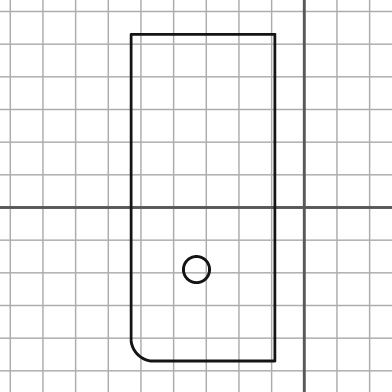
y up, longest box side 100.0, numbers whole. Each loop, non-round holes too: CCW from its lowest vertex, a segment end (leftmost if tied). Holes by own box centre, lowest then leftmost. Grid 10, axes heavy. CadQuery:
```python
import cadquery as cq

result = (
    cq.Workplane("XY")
    .moveTo(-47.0, -47.0)
    .lineTo(-9.0, -47.0)
    .lineTo(-9.0, 53.0)
    .lineTo(-53.0, 53.0)
    .lineTo(-53.0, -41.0)
    .threePointArc((-51.0, -45.0), (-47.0, -47.0))
    .close()
    .moveTo(-33.0, -19.0)
    .circle(4.0)
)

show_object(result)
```